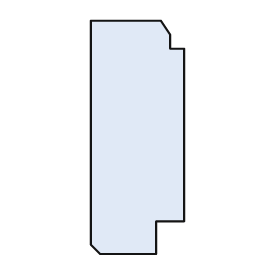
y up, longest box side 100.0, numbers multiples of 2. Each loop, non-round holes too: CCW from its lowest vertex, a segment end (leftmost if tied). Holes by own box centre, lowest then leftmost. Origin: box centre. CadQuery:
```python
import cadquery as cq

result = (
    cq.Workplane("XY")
    .moveTo(-16.0, -50.0)
    .lineTo(8.0, -50.0)
    .lineTo(8.0, -36.0)
    .lineTo(20.0, -36.0)
    .lineTo(20.0, 38.0)
    .lineTo(14.0, 38.0)
    .lineTo(14.0, 44.0)
    .lineTo(10.0, 50.0)
    .lineTo(-20.0, 50.0)
    .lineTo(-20.0, -46.0)
    .close()
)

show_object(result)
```